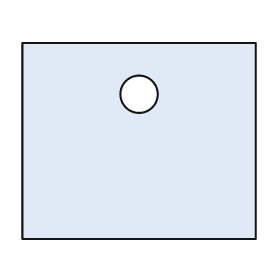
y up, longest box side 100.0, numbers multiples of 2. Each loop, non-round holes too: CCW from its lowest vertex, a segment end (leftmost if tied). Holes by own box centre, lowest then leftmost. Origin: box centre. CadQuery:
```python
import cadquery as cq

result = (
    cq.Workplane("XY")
    .moveTo(-50.0, -42.0)
    .lineTo(50.0, -42.0)
    .lineTo(50.0, 42.0)
    .lineTo(-50.0, 42.0)
    .close()
    .moveTo(0.0, 20.0)
    .circle(8.0)
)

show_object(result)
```